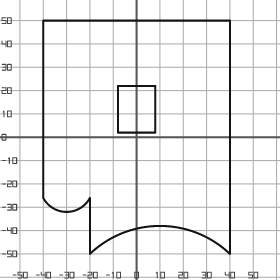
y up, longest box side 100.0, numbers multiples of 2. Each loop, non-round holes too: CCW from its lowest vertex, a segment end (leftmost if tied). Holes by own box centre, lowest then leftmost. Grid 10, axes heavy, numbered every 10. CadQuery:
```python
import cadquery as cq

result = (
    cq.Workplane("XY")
    .moveTo(-20.0, -50.0)
    .threePointArc((10.0, -38.0), (40.0, -50.0))
    .lineTo(40.0, 50.0)
    .lineTo(-40.0, 50.0)
    .lineTo(-40.0, -26.0)
    .threePointArc((-30.0, -32.0), (-20.0, -26.0))
    .close()
    .moveTo(-8.0, 2.0)
    .lineTo(8.0, 2.0)
    .lineTo(8.0, 22.0)
    .lineTo(-8.0, 22.0)
    .close()
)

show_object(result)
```